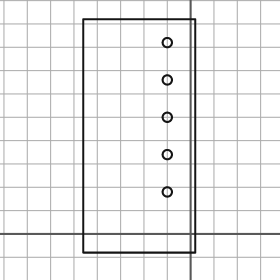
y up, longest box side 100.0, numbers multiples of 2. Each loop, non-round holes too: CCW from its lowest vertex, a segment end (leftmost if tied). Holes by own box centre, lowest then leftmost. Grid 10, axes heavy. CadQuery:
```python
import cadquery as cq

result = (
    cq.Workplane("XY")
    .moveTo(-46.0, -8.0)
    .lineTo(2.0, -8.0)
    .lineTo(2.0, 92.0)
    .lineTo(-46.0, 92.0)
    .close()
    .moveTo(-10.0, 18.0)
    .circle(2.0)
    .moveTo(-10.0, 34.0)
    .circle(2.0)
    .moveTo(-10.0, 50.0)
    .circle(2.0)
    .moveTo(-10.0, 66.0)
    .circle(2.0)
    .moveTo(-10.0, 82.0)
    .circle(2.0)
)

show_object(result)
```